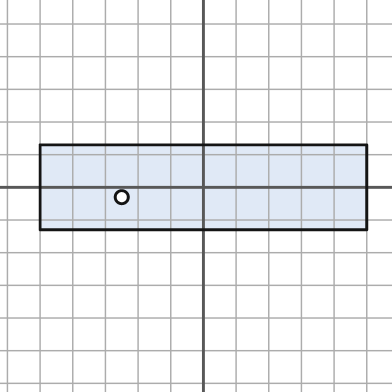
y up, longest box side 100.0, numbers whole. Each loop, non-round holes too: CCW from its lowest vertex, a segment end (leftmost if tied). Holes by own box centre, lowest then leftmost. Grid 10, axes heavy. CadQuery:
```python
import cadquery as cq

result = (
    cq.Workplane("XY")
    .moveTo(-50.0, -13.0)
    .lineTo(50.0, -13.0)
    .lineTo(50.0, 13.0)
    .lineTo(-50.0, 13.0)
    .close()
    .moveTo(-25.0, -3.0)
    .circle(2.0)
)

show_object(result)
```